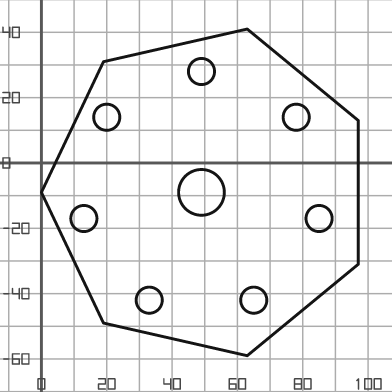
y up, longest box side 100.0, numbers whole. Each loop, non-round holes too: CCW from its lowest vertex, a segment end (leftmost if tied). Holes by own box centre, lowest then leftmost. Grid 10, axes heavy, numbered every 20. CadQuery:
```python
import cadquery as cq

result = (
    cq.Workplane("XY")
    .moveTo(63.0, -59.0)
    .lineTo(97.0, -31.0)
    .lineTo(97.0, 13.0)
    .lineTo(63.0, 41.0)
    .lineTo(19.0, 31.0)
    .lineTo(0.0, -9.0)
    .lineTo(19.0, -49.0)
    .close()
    .moveTo(33.0, -42.0)
    .circle(4.0)
    .moveTo(65.0, -42.0)
    .circle(4.0)
    .moveTo(13.0, -17.0)
    .circle(4.0)
    .moveTo(85.0, -17.0)
    .circle(4.0)
    .moveTo(49.0, -9.0)
    .circle(7.0)
    .moveTo(20.0, 14.0)
    .circle(4.0)
    .moveTo(78.0, 14.0)
    .circle(4.0)
    .moveTo(49.0, 28.0)
    .circle(4.0)
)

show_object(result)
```